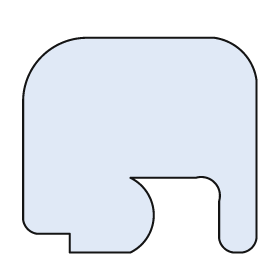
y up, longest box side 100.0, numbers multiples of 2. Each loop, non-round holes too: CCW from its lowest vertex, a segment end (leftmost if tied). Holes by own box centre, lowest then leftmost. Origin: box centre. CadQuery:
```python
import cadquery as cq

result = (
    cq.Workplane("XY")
    .moveTo(-30.0, -46.0)
    .lineTo(-4.0, -46.0)
    .threePointArc((6.0, -30.0), (-4.0, -14.0))
    .lineTo(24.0, -14.0)
    .threePointArc((32.0, -16.0), (34.0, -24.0))
    .lineTo(34.0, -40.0)
    .threePointArc((36.0, -44.0), (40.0, -46.0))
    .lineTo(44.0, -46.0)
    .threePointArc((48.0, -44.0), (50.0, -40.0))
    .lineTo(50.0, 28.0)
    .threePointArc((44.0, 40.0), (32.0, 46.0))
    .lineTo(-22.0, 46.0)
    .threePointArc((-42.0, 38.0), (-50.0, 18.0))
    .lineTo(-50.0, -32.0)
    .threePointArc((-48.0, -36.0), (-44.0, -38.0))
    .lineTo(-30.0, -38.0)
    .close()
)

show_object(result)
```